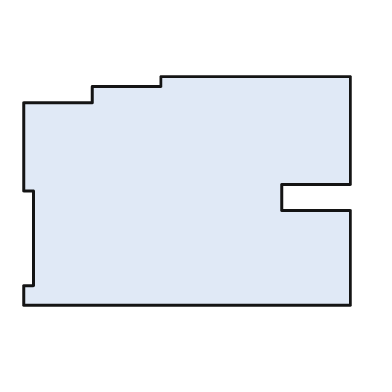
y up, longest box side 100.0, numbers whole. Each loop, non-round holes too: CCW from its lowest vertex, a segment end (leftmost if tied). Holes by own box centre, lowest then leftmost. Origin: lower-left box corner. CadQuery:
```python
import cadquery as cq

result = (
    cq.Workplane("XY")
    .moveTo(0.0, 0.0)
    .lineTo(100.0, 0.0)
    .lineTo(100.0, 29.0)
    .lineTo(79.0, 29.0)
    .lineTo(79.0, 37.0)
    .lineTo(100.0, 37.0)
    .lineTo(100.0, 70.0)
    .lineTo(42.0, 70.0)
    .lineTo(42.0, 67.0)
    .lineTo(21.0, 67.0)
    .lineTo(21.0, 62.0)
    .lineTo(0.0, 62.0)
    .lineTo(0.0, 35.0)
    .lineTo(3.0, 35.0)
    .lineTo(3.0, 6.0)
    .lineTo(0.0, 6.0)
    .close()
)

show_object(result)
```